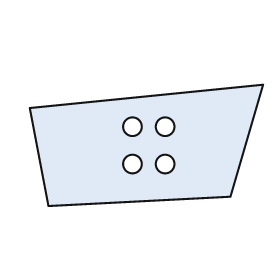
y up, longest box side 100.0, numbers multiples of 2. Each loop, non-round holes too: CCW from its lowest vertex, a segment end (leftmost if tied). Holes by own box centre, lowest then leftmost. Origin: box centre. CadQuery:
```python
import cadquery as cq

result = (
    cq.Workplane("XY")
    .moveTo(-42.0, -26.0)
    .lineTo(36.0, -22.0)
    .lineTo(50.0, 26.0)
    .lineTo(-50.0, 16.0)
    .close()
    .moveTo(-6.0, -8.0)
    .circle(4.0)
    .moveTo(8.0, -8.0)
    .circle(4.0)
    .moveTo(-6.0, 8.0)
    .circle(4.0)
    .moveTo(8.0, 8.0)
    .circle(4.0)
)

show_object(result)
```